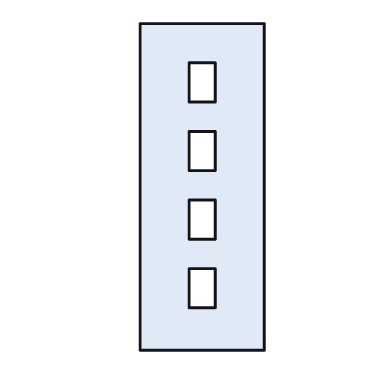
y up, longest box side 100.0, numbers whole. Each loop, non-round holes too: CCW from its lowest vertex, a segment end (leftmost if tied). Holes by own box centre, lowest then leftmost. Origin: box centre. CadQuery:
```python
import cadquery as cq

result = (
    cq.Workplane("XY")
    .moveTo(-19.0, -50.0)
    .lineTo(19.0, -50.0)
    .lineTo(19.0, 50.0)
    .lineTo(-19.0, 50.0)
    .close()
    .moveTo(-4.0, -37.0)
    .lineTo(4.0, -37.0)
    .lineTo(4.0, -25.0)
    .lineTo(-4.0, -25.0)
    .close()
    .moveTo(-4.0, -16.0)
    .lineTo(4.0, -16.0)
    .lineTo(4.0, -4.0)
    .lineTo(-4.0, -4.0)
    .close()
    .moveTo(-4.0, 5.0)
    .lineTo(4.0, 5.0)
    .lineTo(4.0, 17.0)
    .lineTo(-4.0, 17.0)
    .close()
    .moveTo(-4.0, 26.0)
    .lineTo(4.0, 26.0)
    .lineTo(4.0, 38.0)
    .lineTo(-4.0, 38.0)
    .close()
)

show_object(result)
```